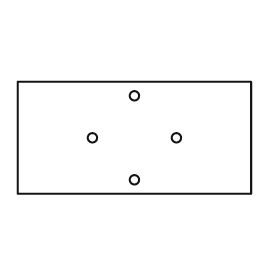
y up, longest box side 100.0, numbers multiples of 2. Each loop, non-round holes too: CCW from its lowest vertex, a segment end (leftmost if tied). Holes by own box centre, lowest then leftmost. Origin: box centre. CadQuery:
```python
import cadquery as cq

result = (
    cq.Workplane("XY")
    .moveTo(-50.0, -24.0)
    .lineTo(50.0, -24.0)
    .lineTo(50.0, 24.0)
    .lineTo(-50.0, 24.0)
    .close()
    .moveTo(0.0, -18.0)
    .circle(2.0)
    .moveTo(-18.0, 0.0)
    .circle(2.0)
    .moveTo(18.0, 0.0)
    .circle(2.0)
    .moveTo(0.0, 18.0)
    .circle(2.0)
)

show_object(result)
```